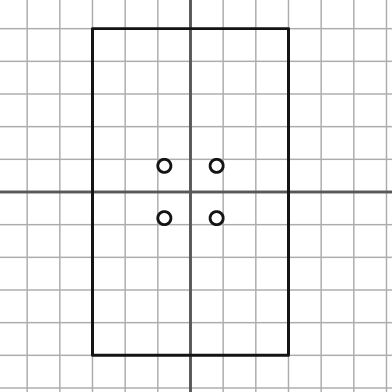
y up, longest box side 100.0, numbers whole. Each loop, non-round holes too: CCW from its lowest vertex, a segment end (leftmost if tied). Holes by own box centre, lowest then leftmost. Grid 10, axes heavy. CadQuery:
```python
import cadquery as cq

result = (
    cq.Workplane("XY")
    .moveTo(-30.0, -50.0)
    .lineTo(30.0, -50.0)
    .lineTo(30.0, 50.0)
    .lineTo(-30.0, 50.0)
    .close()
    .moveTo(-8.0, -8.0)
    .circle(2.0)
    .moveTo(8.0, -8.0)
    .circle(2.0)
    .moveTo(-8.0, 8.0)
    .circle(2.0)
    .moveTo(8.0, 8.0)
    .circle(2.0)
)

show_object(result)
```